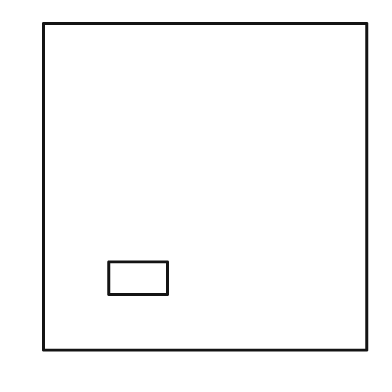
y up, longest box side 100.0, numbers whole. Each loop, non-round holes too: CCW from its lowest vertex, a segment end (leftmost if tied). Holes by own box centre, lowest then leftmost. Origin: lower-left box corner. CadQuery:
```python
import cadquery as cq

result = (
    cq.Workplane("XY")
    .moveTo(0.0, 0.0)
    .lineTo(99.0, 0.0)
    .lineTo(99.0, 100.0)
    .lineTo(0.0, 100.0)
    .close()
    .moveTo(20.0, 17.0)
    .lineTo(38.0, 17.0)
    .lineTo(38.0, 27.0)
    .lineTo(20.0, 27.0)
    .close()
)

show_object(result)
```